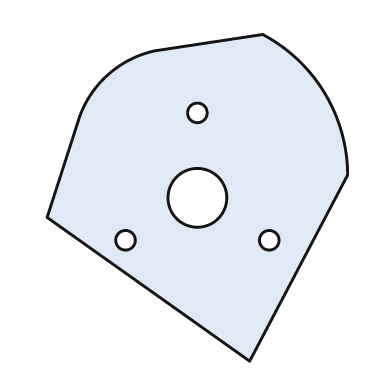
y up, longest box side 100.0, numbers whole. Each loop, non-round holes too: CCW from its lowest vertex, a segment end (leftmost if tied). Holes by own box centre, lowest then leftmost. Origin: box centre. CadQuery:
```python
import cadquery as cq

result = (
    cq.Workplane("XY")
    .moveTo(16.0, -50.0)
    .lineTo(46.0, 7.0)
    .threePointArc((39.0, 32.0), (20.0, 50.0))
    .lineTo(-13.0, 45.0)
    .threePointArc((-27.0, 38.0), (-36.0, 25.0))
    .lineTo(-46.0, -6.0)
    .close()
    .moveTo(-22.0, -13.0)
    .circle(3.0)
    .moveTo(22.0, -13.0)
    .circle(3.0)
    .moveTo(0.0, 0.0)
    .circle(9.0)
    .moveTo(0.0, 26.0)
    .circle(3.0)
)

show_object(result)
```